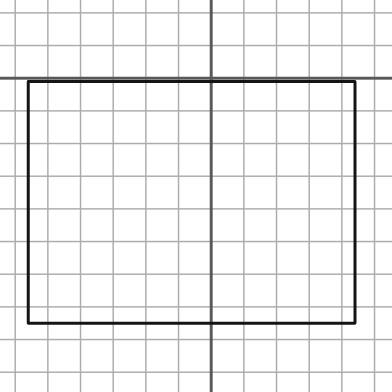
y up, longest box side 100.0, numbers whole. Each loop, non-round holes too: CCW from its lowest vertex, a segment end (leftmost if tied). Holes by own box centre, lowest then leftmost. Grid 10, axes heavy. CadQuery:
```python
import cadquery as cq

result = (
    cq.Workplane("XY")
    .moveTo(-56.0, -75.0)
    .lineTo(44.0, -75.0)
    .lineTo(44.0, -1.0)
    .lineTo(-56.0, -1.0)
    .close()
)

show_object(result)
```